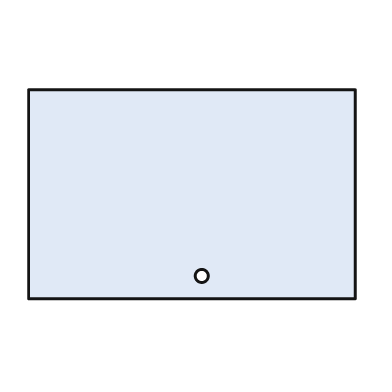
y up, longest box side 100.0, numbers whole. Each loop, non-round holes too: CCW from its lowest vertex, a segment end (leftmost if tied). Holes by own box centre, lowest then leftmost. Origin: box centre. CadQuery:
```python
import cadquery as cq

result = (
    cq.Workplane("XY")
    .moveTo(-50.0, -32.0)
    .lineTo(50.0, -32.0)
    .lineTo(50.0, 32.0)
    .lineTo(-50.0, 32.0)
    .close()
    .moveTo(3.0, -25.0)
    .circle(2.0)
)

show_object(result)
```